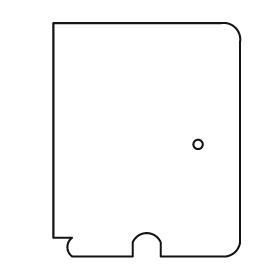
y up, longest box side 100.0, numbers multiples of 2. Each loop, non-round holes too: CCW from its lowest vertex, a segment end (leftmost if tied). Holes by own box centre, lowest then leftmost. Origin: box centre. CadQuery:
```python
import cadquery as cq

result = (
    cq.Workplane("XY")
    .moveTo(-32.0, -50.0)
    .lineTo(-6.0, -50.0)
    .lineTo(-6.0, -44.0)
    .threePointArc((0.0, -40.0), (6.0, -44.0))
    .lineTo(6.0, -50.0)
    .lineTo(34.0, -50.0)
    .threePointArc((38.0, -48.0), (40.0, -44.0))
    .lineTo(40.0, 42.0)
    .threePointArc((38.0, 48.0), (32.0, 50.0))
    .lineTo(-40.0, 50.0)
    .lineTo(-40.0, -42.0)
    .lineTo(-32.0, -42.0)
    .threePointArc((-34.0, -46.0), (-32.0, -50.0))
    .close()
    .moveTo(22.0, -2.0)
    .circle(2.0)
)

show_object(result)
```